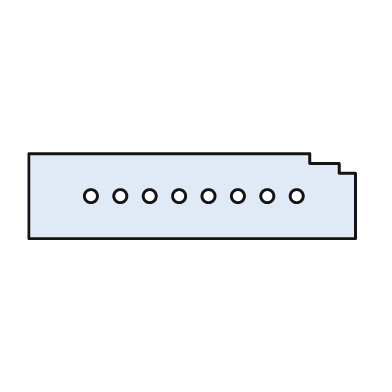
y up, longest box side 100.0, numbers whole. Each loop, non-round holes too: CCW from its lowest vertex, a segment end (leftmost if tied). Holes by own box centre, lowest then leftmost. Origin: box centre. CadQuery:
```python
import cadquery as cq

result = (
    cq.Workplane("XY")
    .moveTo(-50.0, -13.0)
    .lineTo(50.0, -13.0)
    .lineTo(50.0, 7.0)
    .lineTo(45.0, 7.0)
    .lineTo(45.0, 10.0)
    .lineTo(36.0, 10.0)
    .lineTo(36.0, 13.0)
    .lineTo(-50.0, 13.0)
    .close()
    .moveTo(-31.0, 0.0)
    .circle(2.0)
    .moveTo(-22.0, 0.0)
    .circle(2.0)
    .moveTo(-13.0, 0.0)
    .circle(2.0)
    .moveTo(-4.0, 0.0)
    .circle(2.0)
    .moveTo(5.0, 0.0)
    .circle(2.0)
    .moveTo(14.0, 0.0)
    .circle(2.0)
    .moveTo(23.0, 0.0)
    .circle(2.0)
    .moveTo(32.0, 0.0)
    .circle(2.0)
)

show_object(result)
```